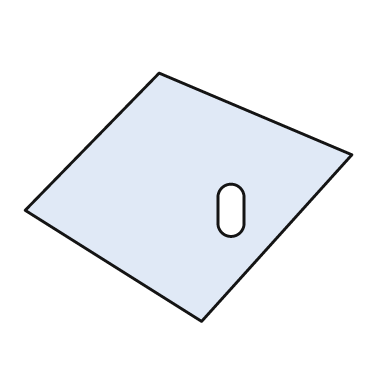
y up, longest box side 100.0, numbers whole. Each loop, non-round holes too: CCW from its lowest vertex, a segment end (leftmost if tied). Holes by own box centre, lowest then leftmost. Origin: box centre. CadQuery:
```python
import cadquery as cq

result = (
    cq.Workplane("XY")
    .moveTo(4.0, -38.0)
    .lineTo(50.0, 13.0)
    .lineTo(-9.0, 38.0)
    .lineTo(-50.0, -4.0)
    .close()
    .moveTo(9.0, -8.0)
    .threePointArc((13.0, -12.0), (17.0, -8.0))
    .lineTo(17.0, 0.0)
    .threePointArc((13.0, 4.0), (9.0, 0.0))
    .close()
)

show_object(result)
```